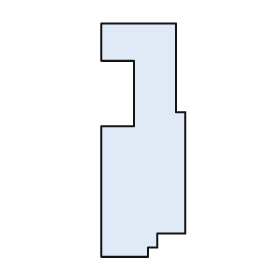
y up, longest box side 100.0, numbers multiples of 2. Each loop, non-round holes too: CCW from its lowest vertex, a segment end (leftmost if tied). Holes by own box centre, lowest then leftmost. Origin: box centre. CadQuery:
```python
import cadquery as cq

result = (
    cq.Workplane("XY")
    .moveTo(-18.0, -50.0)
    .lineTo(2.0, -50.0)
    .lineTo(2.0, -46.0)
    .lineTo(6.0, -46.0)
    .lineTo(6.0, -40.0)
    .lineTo(18.0, -40.0)
    .lineTo(18.0, 12.0)
    .lineTo(14.0, 12.0)
    .lineTo(14.0, 50.0)
    .lineTo(-18.0, 50.0)
    .lineTo(-18.0, 34.0)
    .lineTo(-4.0, 34.0)
    .lineTo(-4.0, 6.0)
    .lineTo(-18.0, 6.0)
    .close()
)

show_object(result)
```